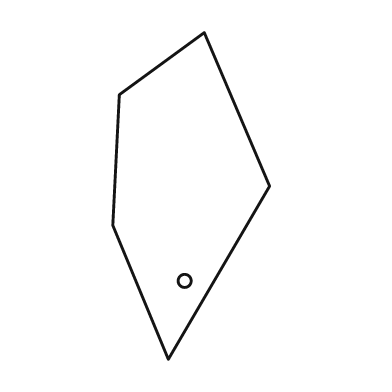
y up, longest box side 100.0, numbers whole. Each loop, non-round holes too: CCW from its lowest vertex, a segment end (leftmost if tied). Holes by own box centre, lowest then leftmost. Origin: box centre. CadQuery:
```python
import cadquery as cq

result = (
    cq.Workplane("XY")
    .moveTo(-7.0, -50.0)
    .lineTo(24.0, 3.0)
    .lineTo(4.0, 50.0)
    .lineTo(-22.0, 31.0)
    .lineTo(-24.0, -9.0)
    .close()
    .moveTo(-2.0, -26.0)
    .circle(2.0)
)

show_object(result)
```